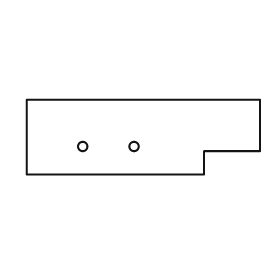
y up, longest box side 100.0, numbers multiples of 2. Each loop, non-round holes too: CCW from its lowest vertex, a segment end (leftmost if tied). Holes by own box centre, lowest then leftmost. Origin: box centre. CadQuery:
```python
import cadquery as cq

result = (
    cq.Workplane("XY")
    .moveTo(-50.0, -16.0)
    .lineTo(26.0, -16.0)
    .lineTo(26.0, -6.0)
    .lineTo(50.0, -6.0)
    .lineTo(50.0, 16.0)
    .lineTo(-50.0, 16.0)
    .close()
    .moveTo(-26.0, -4.0)
    .circle(2.0)
    .moveTo(-4.0, -4.0)
    .circle(2.0)
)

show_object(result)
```